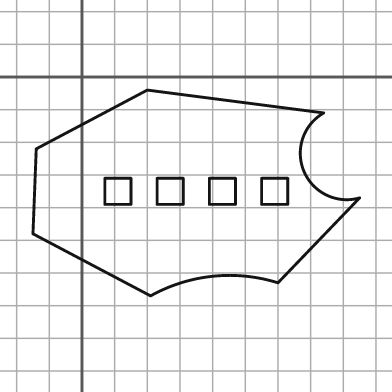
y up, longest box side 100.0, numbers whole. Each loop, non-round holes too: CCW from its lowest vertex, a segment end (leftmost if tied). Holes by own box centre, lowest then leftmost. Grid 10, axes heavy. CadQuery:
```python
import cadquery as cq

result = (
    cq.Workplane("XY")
    .moveTo(21.0, -67.0)
    .threePointArc((40.0, -61.0), (60.0, -63.0))
    .lineTo(85.0, -37.0)
    .threePointArc((68.0, -29.0), (74.0, -11.0))
    .lineTo(20.0, -4.0)
    .lineTo(-14.0, -22.0)
    .lineTo(-15.0, -48.0)
    .close()
    .moveTo(7.0, -39.0)
    .lineTo(15.0, -39.0)
    .lineTo(15.0, -31.0)
    .lineTo(7.0, -31.0)
    .close()
    .moveTo(23.0, -39.0)
    .lineTo(31.0, -39.0)
    .lineTo(31.0, -31.0)
    .lineTo(23.0, -31.0)
    .close()
    .moveTo(39.0, -39.0)
    .lineTo(47.0, -39.0)
    .lineTo(47.0, -31.0)
    .lineTo(39.0, -31.0)
    .close()
    .moveTo(55.0, -39.0)
    .lineTo(63.0, -39.0)
    .lineTo(63.0, -31.0)
    .lineTo(55.0, -31.0)
    .close()
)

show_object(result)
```